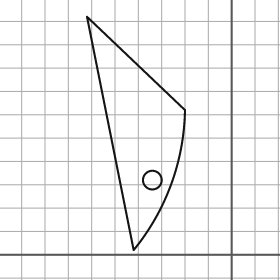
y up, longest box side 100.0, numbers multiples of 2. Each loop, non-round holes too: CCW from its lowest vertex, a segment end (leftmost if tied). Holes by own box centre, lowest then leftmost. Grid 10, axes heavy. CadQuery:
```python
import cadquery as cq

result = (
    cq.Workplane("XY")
    .moveTo(-42.0, 2.0)
    .threePointArc((-26.0, 30.0), (-20.0, 62.0))
    .lineTo(-62.0, 102.0)
    .close()
    .moveTo(-34.0, 32.0)
    .circle(4.0)
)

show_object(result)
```